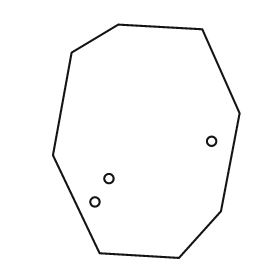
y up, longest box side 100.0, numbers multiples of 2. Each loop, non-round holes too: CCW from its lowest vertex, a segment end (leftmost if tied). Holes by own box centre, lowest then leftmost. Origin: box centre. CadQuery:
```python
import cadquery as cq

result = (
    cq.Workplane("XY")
    .moveTo(14.0, -50.0)
    .lineTo(32.0, -30.0)
    .lineTo(40.0, 12.0)
    .lineTo(24.0, 48.0)
    .lineTo(-12.0, 50.0)
    .lineTo(-32.0, 38.0)
    .lineTo(-40.0, -6.0)
    .lineTo(-20.0, -48.0)
    .close()
    .moveTo(-22.0, -26.0)
    .circle(2.0)
    .moveTo(-16.0, -16.0)
    .circle(2.0)
    .moveTo(28.0, 0.0)
    .circle(2.0)
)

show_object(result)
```